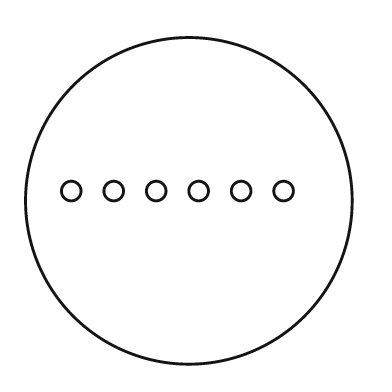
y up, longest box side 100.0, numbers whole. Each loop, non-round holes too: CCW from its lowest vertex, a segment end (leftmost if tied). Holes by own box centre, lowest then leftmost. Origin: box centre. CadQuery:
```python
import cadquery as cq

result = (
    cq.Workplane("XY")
    .moveTo(0.0, 0.0)
    .circle(50.0)
    .moveTo(-36.0, 3.0)
    .circle(3.0)
    .moveTo(-23.0, 3.0)
    .circle(3.0)
    .moveTo(-10.0, 3.0)
    .circle(3.0)
    .moveTo(3.0, 3.0)
    .circle(3.0)
    .moveTo(16.0, 3.0)
    .circle(3.0)
    .moveTo(29.0, 3.0)
    .circle(3.0)
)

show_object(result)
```